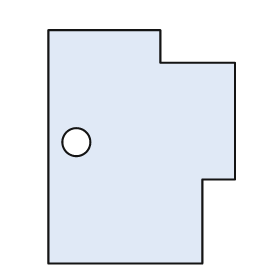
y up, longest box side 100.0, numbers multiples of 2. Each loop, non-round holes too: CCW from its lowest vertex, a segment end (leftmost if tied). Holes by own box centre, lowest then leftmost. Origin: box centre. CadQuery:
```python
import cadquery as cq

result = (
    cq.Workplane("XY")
    .moveTo(-40.0, -50.0)
    .lineTo(26.0, -50.0)
    .lineTo(26.0, -14.0)
    .lineTo(40.0, -14.0)
    .lineTo(40.0, 36.0)
    .lineTo(8.0, 36.0)
    .lineTo(8.0, 50.0)
    .lineTo(-40.0, 50.0)
    .close()
    .moveTo(-28.0, 2.0)
    .circle(6.0)
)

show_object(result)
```